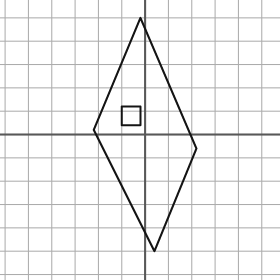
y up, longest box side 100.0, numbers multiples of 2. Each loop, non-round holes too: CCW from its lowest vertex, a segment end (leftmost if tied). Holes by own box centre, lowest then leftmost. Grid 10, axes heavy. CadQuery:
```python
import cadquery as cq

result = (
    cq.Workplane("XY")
    .moveTo(4.0, -50.0)
    .lineTo(22.0, -6.0)
    .lineTo(-2.0, 50.0)
    .lineTo(-22.0, 2.0)
    .close()
    .moveTo(-10.0, 4.0)
    .lineTo(-2.0, 4.0)
    .lineTo(-2.0, 12.0)
    .lineTo(-10.0, 12.0)
    .close()
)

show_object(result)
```